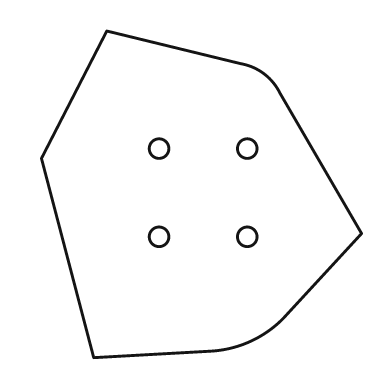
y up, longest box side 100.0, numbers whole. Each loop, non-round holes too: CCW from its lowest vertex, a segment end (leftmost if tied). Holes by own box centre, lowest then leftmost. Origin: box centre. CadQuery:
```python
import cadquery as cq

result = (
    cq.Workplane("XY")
    .moveTo(-33.0, -50.0)
    .lineTo(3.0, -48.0)
    .threePointArc((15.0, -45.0), (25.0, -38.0))
    .lineTo(49.0, -12.0)
    .lineTo(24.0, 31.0)
    .threePointArc((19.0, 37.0), (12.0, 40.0))
    .lineTo(-29.0, 50.0)
    .lineTo(-49.0, 11.0)
    .close()
    .moveTo(-13.0, -13.0)
    .circle(3.0)
    .moveTo(14.0, -13.0)
    .circle(3.0)
    .moveTo(-13.0, 14.0)
    .circle(3.0)
    .moveTo(14.0, 14.0)
    .circle(3.0)
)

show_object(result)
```